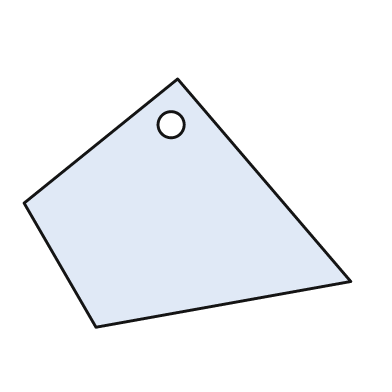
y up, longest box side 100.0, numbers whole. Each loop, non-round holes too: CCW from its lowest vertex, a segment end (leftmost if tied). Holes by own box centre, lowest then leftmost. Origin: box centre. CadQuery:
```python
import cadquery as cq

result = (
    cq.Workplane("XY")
    .moveTo(-28.0, -38.0)
    .lineTo(50.0, -24.0)
    .lineTo(-3.0, 38.0)
    .lineTo(-50.0, 0.0)
    .close()
    .moveTo(-5.0, 24.0)
    .circle(4.0)
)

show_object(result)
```